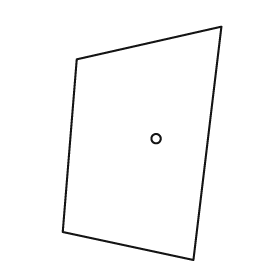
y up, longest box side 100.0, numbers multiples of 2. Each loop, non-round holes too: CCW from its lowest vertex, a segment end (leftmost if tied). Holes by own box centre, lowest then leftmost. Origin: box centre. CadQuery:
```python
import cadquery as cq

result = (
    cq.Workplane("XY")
    .moveTo(22.0, -50.0)
    .lineTo(34.0, 50.0)
    .lineTo(-28.0, 36.0)
    .lineTo(-34.0, -38.0)
    .close()
    .moveTo(6.0, 2.0)
    .circle(2.0)
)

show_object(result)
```